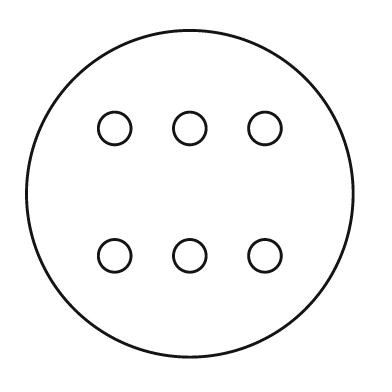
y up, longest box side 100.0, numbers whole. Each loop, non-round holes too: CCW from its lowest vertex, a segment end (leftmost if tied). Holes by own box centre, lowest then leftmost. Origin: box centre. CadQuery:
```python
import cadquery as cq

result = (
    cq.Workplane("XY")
    .moveTo(0.0, 0.0)
    .circle(50.0)
    .moveTo(-23.0, -19.0)
    .circle(5.0)
    .moveTo(0.0, -19.0)
    .circle(5.0)
    .moveTo(23.0, -19.0)
    .circle(5.0)
    .moveTo(-23.0, 20.0)
    .circle(5.0)
    .moveTo(0.0, 20.0)
    .circle(5.0)
    .moveTo(23.0, 20.0)
    .circle(5.0)
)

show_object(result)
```